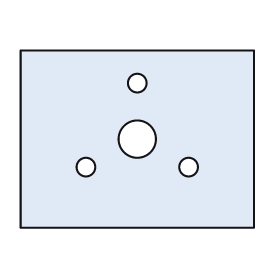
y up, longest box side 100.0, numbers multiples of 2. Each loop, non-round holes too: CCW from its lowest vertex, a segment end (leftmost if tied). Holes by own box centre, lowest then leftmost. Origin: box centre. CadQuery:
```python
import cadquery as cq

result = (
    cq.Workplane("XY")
    .moveTo(-50.0, -38.0)
    .lineTo(50.0, -38.0)
    .lineTo(50.0, 38.0)
    .lineTo(-50.0, 38.0)
    .close()
    .moveTo(-22.0, -12.0)
    .circle(4.0)
    .moveTo(22.0, -12.0)
    .circle(4.0)
    .moveTo(0.0, 0.0)
    .circle(8.0)
    .moveTo(0.0, 24.0)
    .circle(4.0)
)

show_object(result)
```